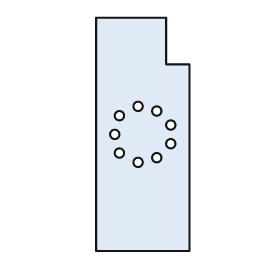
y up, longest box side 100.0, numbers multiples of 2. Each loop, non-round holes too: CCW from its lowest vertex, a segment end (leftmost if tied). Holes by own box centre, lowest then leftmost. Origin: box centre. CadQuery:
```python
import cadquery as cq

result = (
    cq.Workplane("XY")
    .moveTo(-20.0, -50.0)
    .lineTo(20.0, -50.0)
    .lineTo(20.0, 30.0)
    .lineTo(10.0, 30.0)
    .lineTo(10.0, 50.0)
    .lineTo(-20.0, 50.0)
    .close()
    .moveTo(-2.0, -12.0)
    .circle(2.0)
    .moveTo(6.0, -10.0)
    .circle(2.0)
    .moveTo(-10.0, -8.0)
    .circle(2.0)
    .moveTo(12.0, -4.0)
    .circle(2.0)
    .moveTo(-12.0, 0.0)
    .circle(2.0)
    .moveTo(12.0, 4.0)
    .circle(2.0)
    .moveTo(-10.0, 8.0)
    .circle(2.0)
    .moveTo(6.0, 10.0)
    .circle(2.0)
    .moveTo(-2.0, 12.0)
    .circle(2.0)
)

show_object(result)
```